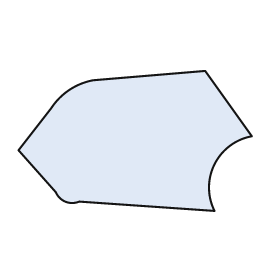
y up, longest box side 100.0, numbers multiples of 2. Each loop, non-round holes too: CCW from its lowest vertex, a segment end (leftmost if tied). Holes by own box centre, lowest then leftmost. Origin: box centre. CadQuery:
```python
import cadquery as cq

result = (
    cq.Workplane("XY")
    .moveTo(34.0, -30.0)
    .threePointArc((34.0, -10.0), (50.0, 2.0))
    .lineTo(30.0, 30.0)
    .lineTo(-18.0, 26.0)
    .threePointArc((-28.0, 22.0), (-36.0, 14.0))
    .lineTo(-50.0, -4.0)
    .lineTo(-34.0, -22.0)
    .threePointArc((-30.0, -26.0), (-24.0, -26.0))
    .close()
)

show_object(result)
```